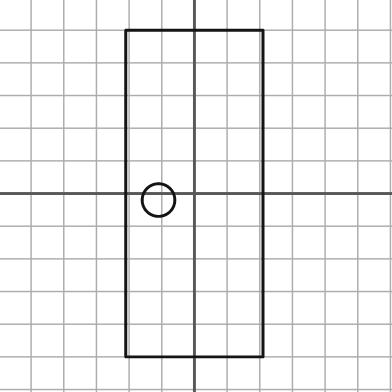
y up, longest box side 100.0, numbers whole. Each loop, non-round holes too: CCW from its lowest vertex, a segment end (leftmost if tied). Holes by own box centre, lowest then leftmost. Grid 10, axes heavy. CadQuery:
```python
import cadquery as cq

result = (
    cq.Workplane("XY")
    .moveTo(-21.0, -50.0)
    .lineTo(21.0, -50.0)
    .lineTo(21.0, 50.0)
    .lineTo(-21.0, 50.0)
    .close()
    .moveTo(-11.0, -2.0)
    .circle(5.0)
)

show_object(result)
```